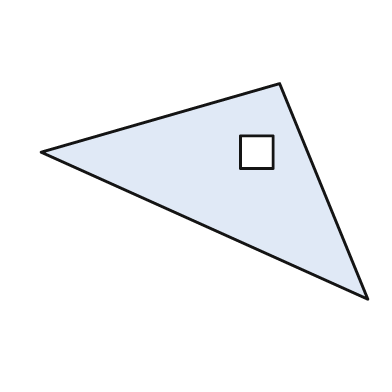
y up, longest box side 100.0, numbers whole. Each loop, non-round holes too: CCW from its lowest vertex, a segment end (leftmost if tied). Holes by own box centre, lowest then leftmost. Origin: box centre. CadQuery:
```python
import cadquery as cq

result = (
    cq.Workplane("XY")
    .moveTo(50.0, -33.0)
    .lineTo(23.0, 33.0)
    .lineTo(-50.0, 12.0)
    .close()
    .moveTo(11.0, 7.0)
    .lineTo(21.0, 7.0)
    .lineTo(21.0, 17.0)
    .lineTo(11.0, 17.0)
    .close()
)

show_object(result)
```